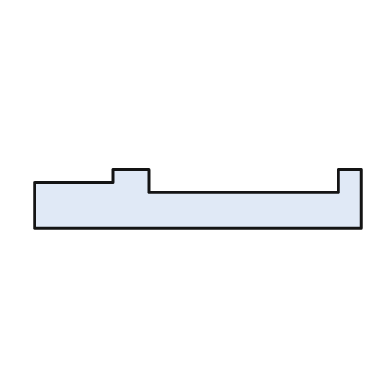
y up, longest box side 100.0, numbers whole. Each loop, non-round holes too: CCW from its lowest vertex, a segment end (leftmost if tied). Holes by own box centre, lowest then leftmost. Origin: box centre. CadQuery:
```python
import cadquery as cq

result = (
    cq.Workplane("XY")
    .moveTo(-50.0, -9.0)
    .lineTo(50.0, -9.0)
    .lineTo(50.0, 9.0)
    .lineTo(43.0, 9.0)
    .lineTo(43.0, 2.0)
    .lineTo(-15.0, 2.0)
    .lineTo(-15.0, 9.0)
    .lineTo(-26.0, 9.0)
    .lineTo(-26.0, 5.0)
    .lineTo(-50.0, 5.0)
    .close()
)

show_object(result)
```